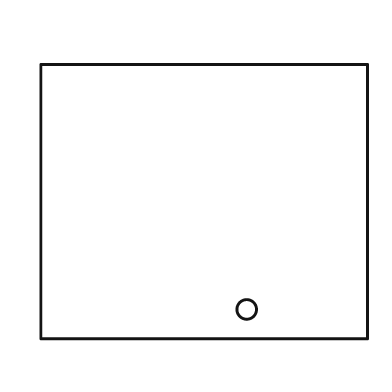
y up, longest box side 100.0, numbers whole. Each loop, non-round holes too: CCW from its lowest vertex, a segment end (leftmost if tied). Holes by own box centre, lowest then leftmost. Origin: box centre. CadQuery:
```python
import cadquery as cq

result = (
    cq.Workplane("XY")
    .moveTo(-50.0, -42.0)
    .lineTo(50.0, -42.0)
    .lineTo(50.0, 42.0)
    .lineTo(-50.0, 42.0)
    .close()
    .moveTo(13.0, -33.0)
    .circle(3.0)
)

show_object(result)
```